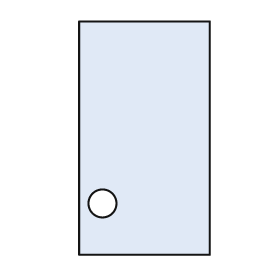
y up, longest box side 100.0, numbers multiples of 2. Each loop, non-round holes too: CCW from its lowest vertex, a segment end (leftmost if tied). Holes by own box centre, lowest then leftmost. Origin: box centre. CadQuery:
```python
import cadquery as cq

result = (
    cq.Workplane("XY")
    .moveTo(-28.0, -50.0)
    .lineTo(28.0, -50.0)
    .lineTo(28.0, 50.0)
    .lineTo(-28.0, 50.0)
    .close()
    .moveTo(-18.0, -28.0)
    .circle(6.0)
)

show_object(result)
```